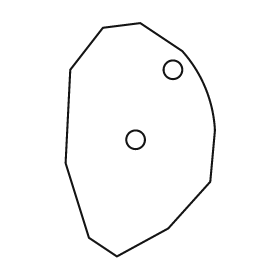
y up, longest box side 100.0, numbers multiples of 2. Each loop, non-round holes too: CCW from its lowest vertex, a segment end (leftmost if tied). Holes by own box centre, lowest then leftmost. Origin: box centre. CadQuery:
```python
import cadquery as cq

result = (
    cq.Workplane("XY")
    .moveTo(-10.0, -50.0)
    .lineTo(12.0, -38.0)
    .lineTo(30.0, -18.0)
    .lineTo(32.0, 4.0)
    .threePointArc((28.0, 22.0), (18.0, 38.0))
    .lineTo(0.0, 50.0)
    .lineTo(-16.0, 48.0)
    .lineTo(-30.0, 30.0)
    .lineTo(-32.0, -10.0)
    .lineTo(-22.0, -42.0)
    .close()
    .moveTo(-2.0, 0.0)
    .circle(4.0)
    .moveTo(14.0, 30.0)
    .circle(4.0)
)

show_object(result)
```